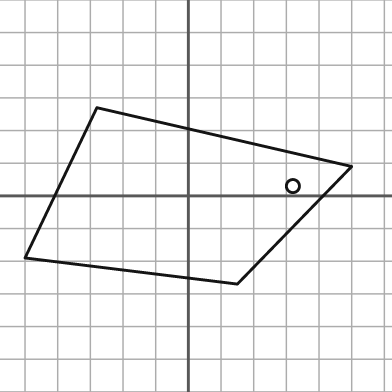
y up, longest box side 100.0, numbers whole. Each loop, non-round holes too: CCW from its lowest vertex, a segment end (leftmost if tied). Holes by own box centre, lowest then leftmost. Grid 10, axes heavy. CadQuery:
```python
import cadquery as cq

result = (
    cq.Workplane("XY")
    .moveTo(15.0, -27.0)
    .lineTo(50.0, 9.0)
    .lineTo(-28.0, 27.0)
    .lineTo(-50.0, -19.0)
    .close()
    .moveTo(32.0, 3.0)
    .circle(2.0)
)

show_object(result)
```